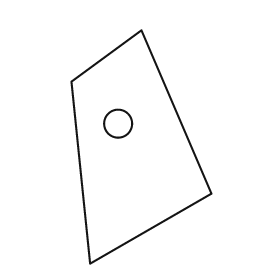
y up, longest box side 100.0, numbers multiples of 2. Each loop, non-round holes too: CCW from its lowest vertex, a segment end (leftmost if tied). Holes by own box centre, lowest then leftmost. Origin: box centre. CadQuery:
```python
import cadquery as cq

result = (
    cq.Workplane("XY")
    .moveTo(-22.0, -50.0)
    .lineTo(30.0, -20.0)
    .lineTo(0.0, 50.0)
    .lineTo(-30.0, 28.0)
    .close()
    .moveTo(-10.0, 10.0)
    .circle(6.0)
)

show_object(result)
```